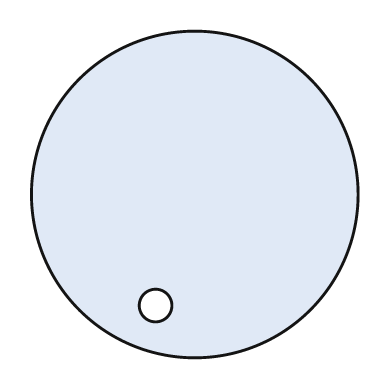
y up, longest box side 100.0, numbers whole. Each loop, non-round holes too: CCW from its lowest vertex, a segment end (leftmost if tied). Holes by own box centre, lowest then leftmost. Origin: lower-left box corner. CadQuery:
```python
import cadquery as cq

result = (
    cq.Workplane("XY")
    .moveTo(50.0, 50.0)
    .circle(50.0)
    .moveTo(38.0, 16.0)
    .circle(5.0)
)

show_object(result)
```